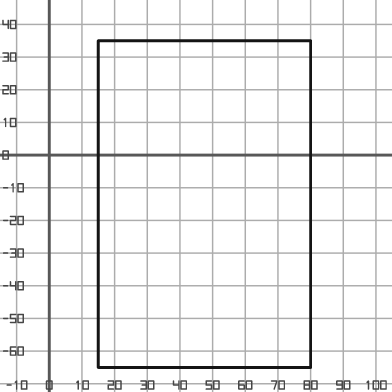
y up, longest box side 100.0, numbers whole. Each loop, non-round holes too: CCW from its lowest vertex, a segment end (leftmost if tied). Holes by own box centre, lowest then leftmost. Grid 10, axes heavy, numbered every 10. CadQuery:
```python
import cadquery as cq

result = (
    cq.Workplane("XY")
    .moveTo(15.0, -65.0)
    .lineTo(80.0, -65.0)
    .lineTo(80.0, 35.0)
    .lineTo(15.0, 35.0)
    .close()
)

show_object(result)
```